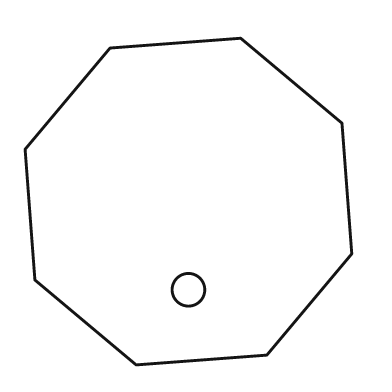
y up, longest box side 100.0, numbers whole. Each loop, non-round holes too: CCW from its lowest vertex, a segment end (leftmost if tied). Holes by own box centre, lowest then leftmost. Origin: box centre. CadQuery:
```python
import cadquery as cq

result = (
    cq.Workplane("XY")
    .moveTo(-16.0, -50.0)
    .lineTo(24.0, -47.0)
    .lineTo(50.0, -16.0)
    .lineTo(47.0, 24.0)
    .lineTo(16.0, 50.0)
    .lineTo(-24.0, 47.0)
    .lineTo(-50.0, 16.0)
    .lineTo(-47.0, -24.0)
    .close()
    .moveTo(0.0, -27.0)
    .circle(5.0)
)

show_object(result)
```